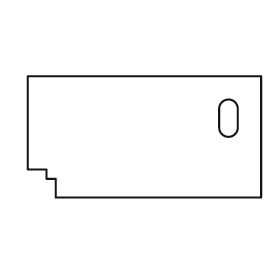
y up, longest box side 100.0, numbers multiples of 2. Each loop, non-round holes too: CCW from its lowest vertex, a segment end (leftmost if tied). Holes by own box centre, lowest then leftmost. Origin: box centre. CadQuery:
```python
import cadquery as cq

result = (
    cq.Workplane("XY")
    .moveTo(-38.0, -26.0)
    .lineTo(50.0, -26.0)
    .lineTo(50.0, 26.0)
    .lineTo(-50.0, 26.0)
    .lineTo(-50.0, -14.0)
    .lineTo(-42.0, -14.0)
    .lineTo(-42.0, -18.0)
    .lineTo(-38.0, -18.0)
    .close()
    .moveTo(32.0, 4.0)
    .threePointArc((36.0, 0.0), (40.0, 4.0))
    .lineTo(40.0, 12.0)
    .threePointArc((36.0, 16.0), (32.0, 12.0))
    .close()
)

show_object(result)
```